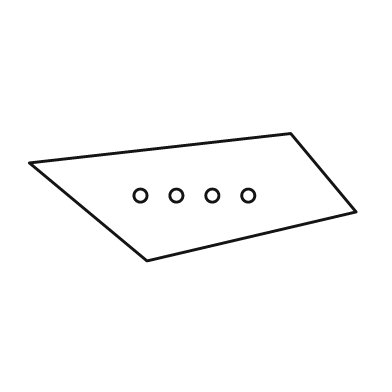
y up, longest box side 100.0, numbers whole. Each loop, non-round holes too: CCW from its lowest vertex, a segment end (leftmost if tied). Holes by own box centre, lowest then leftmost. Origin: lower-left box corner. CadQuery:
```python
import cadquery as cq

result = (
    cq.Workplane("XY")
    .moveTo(36.0, 0.0)
    .lineTo(100.0, 15.0)
    .lineTo(80.0, 39.0)
    .lineTo(0.0, 30.0)
    .close()
    .moveTo(34.0, 20.0)
    .circle(2.0)
    .moveTo(45.0, 20.0)
    .circle(2.0)
    .moveTo(56.0, 20.0)
    .circle(2.0)
    .moveTo(67.0, 20.0)
    .circle(2.0)
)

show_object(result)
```